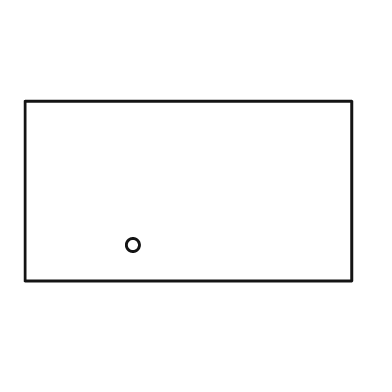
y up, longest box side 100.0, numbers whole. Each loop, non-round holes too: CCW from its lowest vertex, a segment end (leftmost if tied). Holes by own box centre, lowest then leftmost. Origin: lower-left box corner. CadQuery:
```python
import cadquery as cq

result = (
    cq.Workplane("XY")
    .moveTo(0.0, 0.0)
    .lineTo(100.0, 0.0)
    .lineTo(100.0, 55.0)
    .lineTo(0.0, 55.0)
    .close()
    .moveTo(33.0, 11.0)
    .circle(2.0)
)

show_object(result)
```